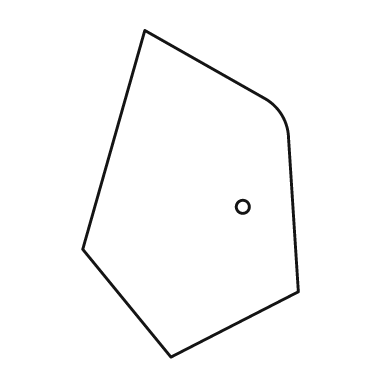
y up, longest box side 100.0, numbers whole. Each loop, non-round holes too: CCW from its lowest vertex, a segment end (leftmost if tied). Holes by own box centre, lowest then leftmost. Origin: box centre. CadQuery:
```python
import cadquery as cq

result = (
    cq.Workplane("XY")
    .moveTo(-6.0, -50.0)
    .lineTo(33.0, -30.0)
    .lineTo(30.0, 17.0)
    .threePointArc((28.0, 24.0), (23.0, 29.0))
    .lineTo(-14.0, 50.0)
    .lineTo(-33.0, -17.0)
    .close()
    .moveTo(16.0, -4.0)
    .circle(2.0)
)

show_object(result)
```